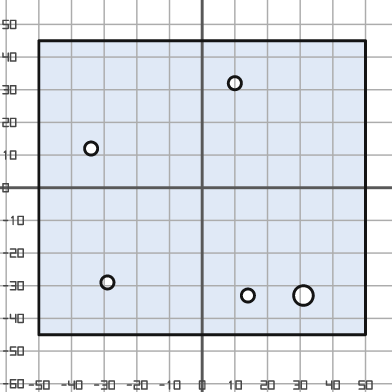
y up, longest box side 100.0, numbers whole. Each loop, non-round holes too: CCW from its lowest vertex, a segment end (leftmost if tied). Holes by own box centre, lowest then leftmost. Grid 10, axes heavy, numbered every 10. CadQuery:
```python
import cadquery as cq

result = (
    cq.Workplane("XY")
    .moveTo(-50.0, -45.0)
    .lineTo(50.0, -45.0)
    .lineTo(50.0, 45.0)
    .lineTo(-50.0, 45.0)
    .close()
    .moveTo(14.0, -33.0)
    .circle(2.0)
    .moveTo(31.0, -33.0)
    .circle(3.0)
    .moveTo(-29.0, -29.0)
    .circle(2.0)
    .moveTo(-34.0, 12.0)
    .circle(2.0)
    .moveTo(10.0, 32.0)
    .circle(2.0)
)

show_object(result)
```